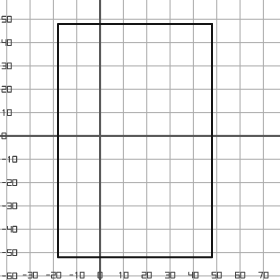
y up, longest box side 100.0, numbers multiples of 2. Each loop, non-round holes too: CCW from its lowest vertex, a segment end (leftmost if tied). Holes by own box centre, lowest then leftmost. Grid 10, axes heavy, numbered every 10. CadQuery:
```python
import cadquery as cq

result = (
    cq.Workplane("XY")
    .moveTo(-18.0, -52.0)
    .lineTo(48.0, -52.0)
    .lineTo(48.0, 48.0)
    .lineTo(-18.0, 48.0)
    .close()
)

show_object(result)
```